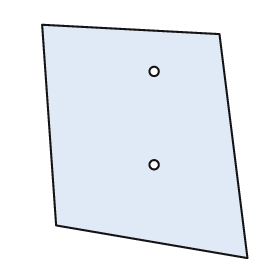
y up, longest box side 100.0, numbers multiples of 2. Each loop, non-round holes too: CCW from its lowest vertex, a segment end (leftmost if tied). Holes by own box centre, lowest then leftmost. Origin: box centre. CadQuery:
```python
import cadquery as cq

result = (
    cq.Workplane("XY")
    .moveTo(44.0, -50.0)
    .lineTo(32.0, 46.0)
    .lineTo(-44.0, 50.0)
    .lineTo(-38.0, -36.0)
    .close()
    .moveTo(4.0, -10.0)
    .circle(2.0)
    .moveTo(4.0, 30.0)
    .circle(2.0)
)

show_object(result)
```